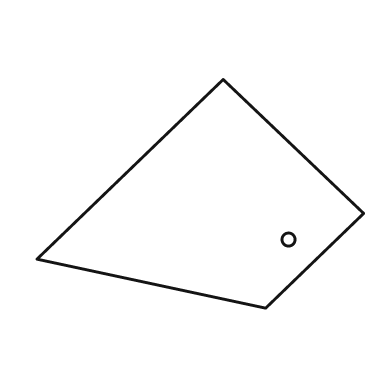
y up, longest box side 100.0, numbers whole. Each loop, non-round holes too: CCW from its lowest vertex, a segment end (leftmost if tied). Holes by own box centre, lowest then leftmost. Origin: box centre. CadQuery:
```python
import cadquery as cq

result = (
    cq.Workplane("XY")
    .moveTo(20.0, -35.0)
    .lineTo(50.0, -6.0)
    .lineTo(7.0, 35.0)
    .lineTo(-50.0, -20.0)
    .close()
    .moveTo(27.0, -14.0)
    .circle(2.0)
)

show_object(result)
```